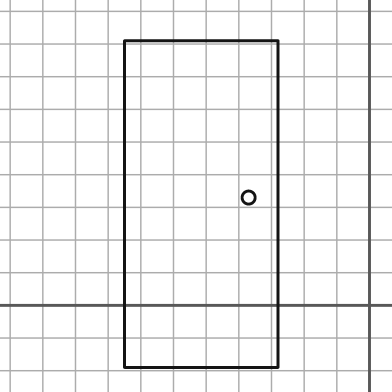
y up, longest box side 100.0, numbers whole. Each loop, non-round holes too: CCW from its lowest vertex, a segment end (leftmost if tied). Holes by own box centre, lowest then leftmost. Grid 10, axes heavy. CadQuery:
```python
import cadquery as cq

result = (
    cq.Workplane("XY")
    .moveTo(-75.0, -19.0)
    .lineTo(-28.0, -19.0)
    .lineTo(-28.0, 81.0)
    .lineTo(-75.0, 81.0)
    .close()
    .moveTo(-37.0, 33.0)
    .circle(2.0)
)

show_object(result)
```